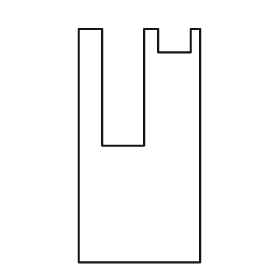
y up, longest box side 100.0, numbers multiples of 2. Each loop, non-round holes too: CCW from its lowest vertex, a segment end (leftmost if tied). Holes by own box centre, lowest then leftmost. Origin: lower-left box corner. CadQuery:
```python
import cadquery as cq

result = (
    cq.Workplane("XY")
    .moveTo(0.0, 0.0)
    .lineTo(52.0, 0.0)
    .lineTo(52.0, 100.0)
    .lineTo(48.0, 100.0)
    .lineTo(48.0, 90.0)
    .lineTo(34.0, 90.0)
    .lineTo(34.0, 100.0)
    .lineTo(28.0, 100.0)
    .lineTo(28.0, 50.0)
    .lineTo(10.0, 50.0)
    .lineTo(10.0, 100.0)
    .lineTo(0.0, 100.0)
    .close()
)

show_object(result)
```